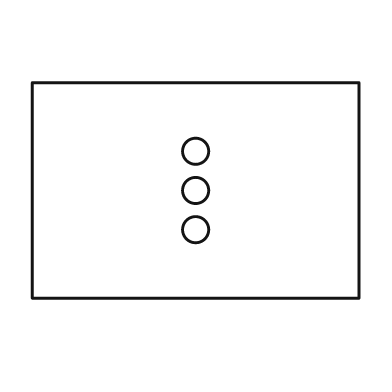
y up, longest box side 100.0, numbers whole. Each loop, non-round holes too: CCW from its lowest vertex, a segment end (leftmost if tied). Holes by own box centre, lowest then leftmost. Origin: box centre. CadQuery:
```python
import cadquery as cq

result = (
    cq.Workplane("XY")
    .moveTo(-50.0, -33.0)
    .lineTo(50.0, -33.0)
    .lineTo(50.0, 33.0)
    .lineTo(-50.0, 33.0)
    .close()
    .moveTo(0.0, -12.0)
    .circle(4.0)
    .moveTo(0.0, 0.0)
    .circle(4.0)
    .moveTo(0.0, 12.0)
    .circle(4.0)
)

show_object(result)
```